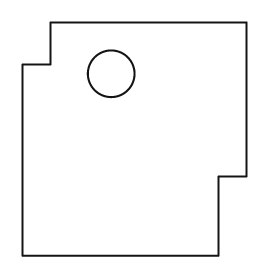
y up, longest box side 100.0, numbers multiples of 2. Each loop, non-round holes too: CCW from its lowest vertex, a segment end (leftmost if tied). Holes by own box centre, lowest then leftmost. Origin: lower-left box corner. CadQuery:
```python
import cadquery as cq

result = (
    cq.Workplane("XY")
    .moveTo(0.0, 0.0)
    .lineTo(84.0, 0.0)
    .lineTo(84.0, 34.0)
    .lineTo(96.0, 34.0)
    .lineTo(96.0, 100.0)
    .lineTo(12.0, 100.0)
    .lineTo(12.0, 82.0)
    .lineTo(0.0, 82.0)
    .close()
    .moveTo(38.0, 78.0)
    .circle(10.0)
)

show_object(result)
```